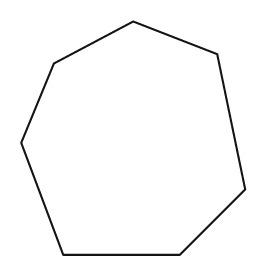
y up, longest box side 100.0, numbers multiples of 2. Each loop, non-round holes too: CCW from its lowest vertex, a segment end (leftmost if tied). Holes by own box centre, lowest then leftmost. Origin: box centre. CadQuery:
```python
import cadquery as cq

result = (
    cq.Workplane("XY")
    .moveTo(-30.0, -50.0)
    .lineTo(20.0, -50.0)
    .lineTo(48.0, -22.0)
    .lineTo(36.0, 36.0)
    .lineTo(0.0, 50.0)
    .lineTo(-34.0, 32.0)
    .lineTo(-48.0, -2.0)
    .close()
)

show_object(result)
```